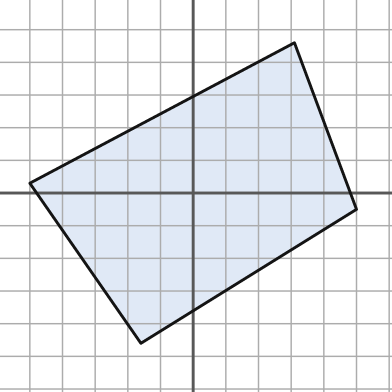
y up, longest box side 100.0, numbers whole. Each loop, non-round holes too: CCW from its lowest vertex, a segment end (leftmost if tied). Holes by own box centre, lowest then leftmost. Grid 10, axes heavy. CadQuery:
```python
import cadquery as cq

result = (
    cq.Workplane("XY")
    .moveTo(-16.0, -46.0)
    .lineTo(50.0, -5.0)
    .lineTo(31.0, 46.0)
    .lineTo(-50.0, 3.0)
    .close()
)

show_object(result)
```